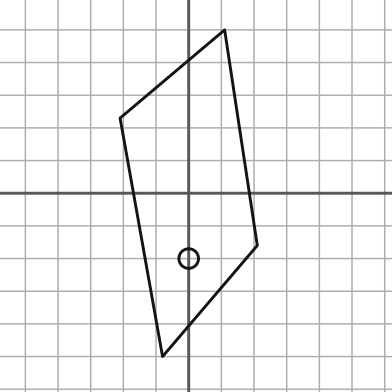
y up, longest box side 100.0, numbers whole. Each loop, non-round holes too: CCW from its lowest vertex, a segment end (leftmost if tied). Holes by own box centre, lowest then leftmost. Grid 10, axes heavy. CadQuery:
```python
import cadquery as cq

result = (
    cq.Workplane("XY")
    .moveTo(-8.0, -50.0)
    .lineTo(21.0, -16.0)
    .lineTo(11.0, 50.0)
    .lineTo(-21.0, 23.0)
    .close()
    .moveTo(0.0, -20.0)
    .circle(3.0)
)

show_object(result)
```